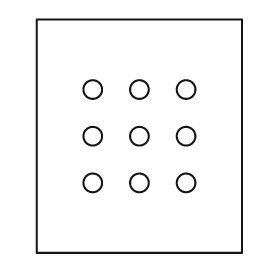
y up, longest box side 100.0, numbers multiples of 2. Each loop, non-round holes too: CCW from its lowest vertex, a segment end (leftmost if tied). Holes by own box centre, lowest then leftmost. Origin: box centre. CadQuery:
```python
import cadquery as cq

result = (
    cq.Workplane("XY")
    .moveTo(-44.0, -50.0)
    .lineTo(44.0, -50.0)
    .lineTo(44.0, 50.0)
    .lineTo(-44.0, 50.0)
    .close()
    .moveTo(-20.0, -20.0)
    .circle(4.0)
    .moveTo(0.0, -20.0)
    .circle(4.0)
    .moveTo(20.0, -20.0)
    .circle(4.0)
    .moveTo(-20.0, 0.0)
    .circle(4.0)
    .moveTo(0.0, 0.0)
    .circle(4.0)
    .moveTo(20.0, 0.0)
    .circle(4.0)
    .moveTo(-20.0, 20.0)
    .circle(4.0)
    .moveTo(0.0, 20.0)
    .circle(4.0)
    .moveTo(20.0, 20.0)
    .circle(4.0)
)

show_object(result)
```